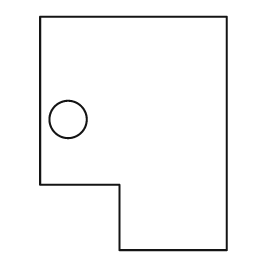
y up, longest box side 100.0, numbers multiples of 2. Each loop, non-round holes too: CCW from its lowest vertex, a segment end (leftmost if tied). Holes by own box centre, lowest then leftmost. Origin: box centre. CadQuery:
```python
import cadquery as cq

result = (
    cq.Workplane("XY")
    .moveTo(-6.0, -50.0)
    .lineTo(40.0, -50.0)
    .lineTo(40.0, 50.0)
    .lineTo(-40.0, 50.0)
    .lineTo(-40.0, -22.0)
    .lineTo(-6.0, -22.0)
    .close()
    .moveTo(-28.0, 6.0)
    .circle(8.0)
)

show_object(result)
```